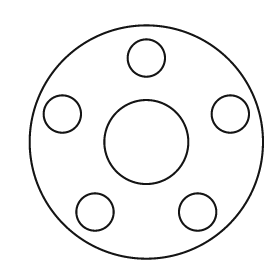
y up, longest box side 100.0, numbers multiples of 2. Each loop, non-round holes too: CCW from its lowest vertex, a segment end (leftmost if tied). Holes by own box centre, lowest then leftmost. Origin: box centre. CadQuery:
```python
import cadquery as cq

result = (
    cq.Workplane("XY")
    .moveTo(0.0, 0.0)
    .circle(50.0)
    .moveTo(-22.0, -30.0)
    .circle(8.0)
    .moveTo(22.0, -30.0)
    .circle(8.0)
    .moveTo(0.0, 0.0)
    .circle(18.0)
    .moveTo(-36.0, 12.0)
    .circle(8.0)
    .moveTo(36.0, 12.0)
    .circle(8.0)
    .moveTo(0.0, 36.0)
    .circle(8.0)
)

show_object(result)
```